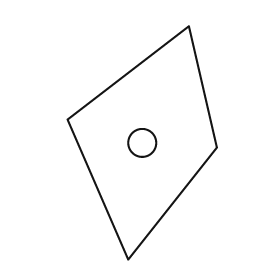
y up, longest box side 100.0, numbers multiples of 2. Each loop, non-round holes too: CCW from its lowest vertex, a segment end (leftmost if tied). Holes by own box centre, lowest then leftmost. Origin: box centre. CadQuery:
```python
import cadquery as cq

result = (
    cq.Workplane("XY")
    .moveTo(-6.0, -50.0)
    .lineTo(32.0, -2.0)
    .lineTo(20.0, 50.0)
    .lineTo(-32.0, 10.0)
    .close()
    .moveTo(0.0, 0.0)
    .circle(6.0)
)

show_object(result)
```